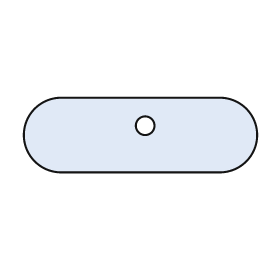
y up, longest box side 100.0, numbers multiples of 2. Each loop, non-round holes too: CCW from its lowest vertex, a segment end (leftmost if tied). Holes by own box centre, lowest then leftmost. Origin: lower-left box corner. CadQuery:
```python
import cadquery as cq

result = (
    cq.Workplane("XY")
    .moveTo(16.0, 0.0)
    .lineTo(84.0, 0.0)
    .threePointArc((100.0, 16.0), (84.0, 32.0))
    .lineTo(16.0, 32.0)
    .threePointArc((0.0, 16.0), (16.0, 0.0))
    .close()
    .moveTo(52.0, 20.0)
    .circle(4.0)
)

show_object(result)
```